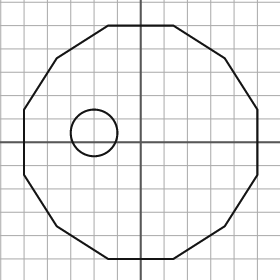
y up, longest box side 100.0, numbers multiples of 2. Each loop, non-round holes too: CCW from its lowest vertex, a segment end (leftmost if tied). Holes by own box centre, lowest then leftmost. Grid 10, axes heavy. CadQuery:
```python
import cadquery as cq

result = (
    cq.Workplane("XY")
    .moveTo(-14.0, -50.0)
    .lineTo(14.0, -50.0)
    .lineTo(36.0, -36.0)
    .lineTo(50.0, -14.0)
    .lineTo(50.0, 14.0)
    .lineTo(36.0, 36.0)
    .lineTo(14.0, 50.0)
    .lineTo(-14.0, 50.0)
    .lineTo(-36.0, 36.0)
    .lineTo(-50.0, 14.0)
    .lineTo(-50.0, -14.0)
    .lineTo(-36.0, -36.0)
    .close()
    .moveTo(-20.0, 4.0)
    .circle(10.0)
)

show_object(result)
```